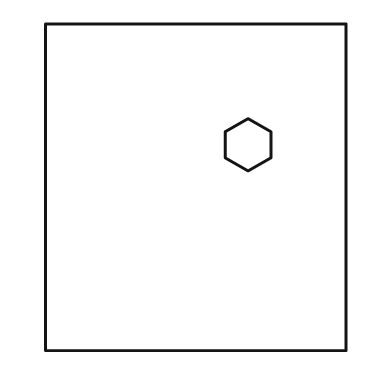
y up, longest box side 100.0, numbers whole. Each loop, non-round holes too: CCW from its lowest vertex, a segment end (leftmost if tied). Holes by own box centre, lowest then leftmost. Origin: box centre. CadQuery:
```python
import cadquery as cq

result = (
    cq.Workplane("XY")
    .moveTo(-46.0, -50.0)
    .lineTo(46.0, -50.0)
    .lineTo(46.0, 50.0)
    .lineTo(-46.0, 50.0)
    .close()
    .moveTo(16.0, 5.0)
    .lineTo(23.0, 9.0)
    .lineTo(23.0, 17.0)
    .lineTo(16.0, 21.0)
    .lineTo(9.0, 17.0)
    .lineTo(9.0, 9.0)
    .close()
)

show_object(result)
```